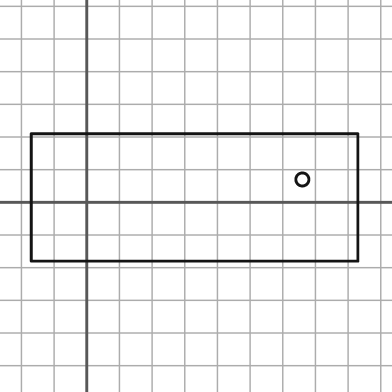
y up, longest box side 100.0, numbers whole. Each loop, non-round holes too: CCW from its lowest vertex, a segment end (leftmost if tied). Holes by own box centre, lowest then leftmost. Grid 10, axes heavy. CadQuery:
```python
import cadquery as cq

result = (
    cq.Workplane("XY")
    .moveTo(-17.0, -18.0)
    .lineTo(83.0, -18.0)
    .lineTo(83.0, 21.0)
    .lineTo(-17.0, 21.0)
    .close()
    .moveTo(66.0, 7.0)
    .circle(2.0)
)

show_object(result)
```